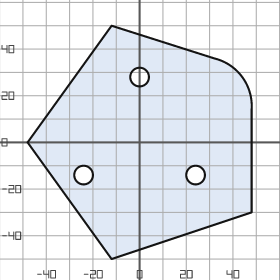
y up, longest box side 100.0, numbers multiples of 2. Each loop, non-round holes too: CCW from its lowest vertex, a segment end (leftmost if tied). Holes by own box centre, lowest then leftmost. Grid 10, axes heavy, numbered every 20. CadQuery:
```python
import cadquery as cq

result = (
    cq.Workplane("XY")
    .moveTo(-12.0, -50.0)
    .lineTo(48.0, -30.0)
    .lineTo(48.0, 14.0)
    .threePointArc((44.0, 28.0), (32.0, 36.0))
    .lineTo(-12.0, 50.0)
    .lineTo(-48.0, 0.0)
    .close()
    .moveTo(-24.0, -14.0)
    .circle(4.0)
    .moveTo(24.0, -14.0)
    .circle(4.0)
    .moveTo(0.0, 28.0)
    .circle(4.0)
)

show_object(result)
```